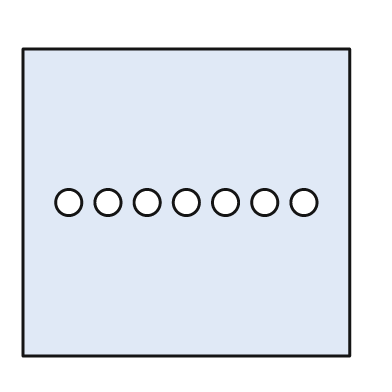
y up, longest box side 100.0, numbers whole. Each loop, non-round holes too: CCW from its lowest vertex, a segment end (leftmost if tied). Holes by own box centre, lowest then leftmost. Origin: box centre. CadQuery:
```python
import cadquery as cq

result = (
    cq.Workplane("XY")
    .moveTo(-50.0, -47.0)
    .lineTo(50.0, -47.0)
    .lineTo(50.0, 47.0)
    .lineTo(-50.0, 47.0)
    .close()
    .moveTo(-36.0, 0.0)
    .circle(4.0)
    .moveTo(-24.0, 0.0)
    .circle(4.0)
    .moveTo(-12.0, 0.0)
    .circle(4.0)
    .moveTo(0.0, 0.0)
    .circle(4.0)
    .moveTo(12.0, 0.0)
    .circle(4.0)
    .moveTo(24.0, 0.0)
    .circle(4.0)
    .moveTo(36.0, 0.0)
    .circle(4.0)
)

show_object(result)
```